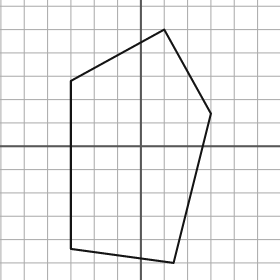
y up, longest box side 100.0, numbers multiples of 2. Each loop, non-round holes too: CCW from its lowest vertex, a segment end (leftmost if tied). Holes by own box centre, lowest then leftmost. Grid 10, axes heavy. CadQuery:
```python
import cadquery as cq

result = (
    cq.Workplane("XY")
    .moveTo(14.0, -50.0)
    .lineTo(30.0, 14.0)
    .lineTo(10.0, 50.0)
    .lineTo(-30.0, 28.0)
    .lineTo(-30.0, -44.0)
    .close()
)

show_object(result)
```